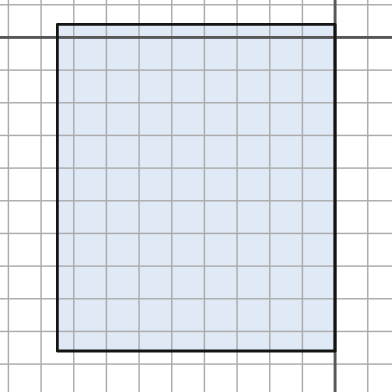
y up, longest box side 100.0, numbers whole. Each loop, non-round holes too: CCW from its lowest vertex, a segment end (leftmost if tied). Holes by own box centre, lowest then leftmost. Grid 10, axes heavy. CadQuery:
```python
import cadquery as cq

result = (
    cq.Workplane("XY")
    .moveTo(-85.0, -96.0)
    .lineTo(0.0, -96.0)
    .lineTo(0.0, 4.0)
    .lineTo(-85.0, 4.0)
    .close()
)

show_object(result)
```